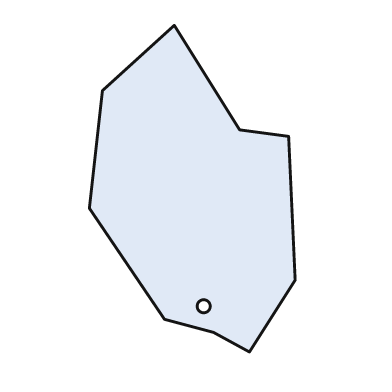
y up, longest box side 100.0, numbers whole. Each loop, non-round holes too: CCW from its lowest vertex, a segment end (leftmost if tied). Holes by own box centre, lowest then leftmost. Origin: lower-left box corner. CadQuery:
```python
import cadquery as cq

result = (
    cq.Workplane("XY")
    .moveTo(49.0, 0.0)
    .lineTo(63.0, 22.0)
    .lineTo(61.0, 66.0)
    .lineTo(46.0, 68.0)
    .lineTo(26.0, 100.0)
    .lineTo(4.0, 80.0)
    .lineTo(0.0, 44.0)
    .lineTo(23.0, 10.0)
    .lineTo(38.0, 6.0)
    .close()
    .moveTo(35.0, 14.0)
    .circle(2.0)
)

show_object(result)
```